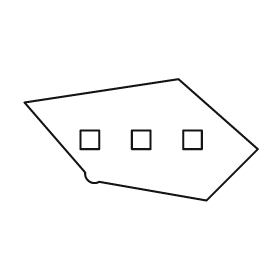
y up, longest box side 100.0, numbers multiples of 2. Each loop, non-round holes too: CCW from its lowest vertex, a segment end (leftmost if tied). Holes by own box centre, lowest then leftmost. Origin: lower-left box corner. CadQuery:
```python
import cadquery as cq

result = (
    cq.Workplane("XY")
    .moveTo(78.0, 0.0)
    .lineTo(100.0, 22.0)
    .lineTo(66.0, 52.0)
    .lineTo(0.0, 42.0)
    .lineTo(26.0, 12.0)
    .threePointArc((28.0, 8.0), (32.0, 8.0))
    .close()
    .moveTo(24.0, 22.0)
    .lineTo(32.0, 22.0)
    .lineTo(32.0, 30.0)
    .lineTo(24.0, 30.0)
    .close()
    .moveTo(46.0, 22.0)
    .lineTo(54.0, 22.0)
    .lineTo(54.0, 30.0)
    .lineTo(46.0, 30.0)
    .close()
    .moveTo(68.0, 22.0)
    .lineTo(76.0, 22.0)
    .lineTo(76.0, 30.0)
    .lineTo(68.0, 30.0)
    .close()
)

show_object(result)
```